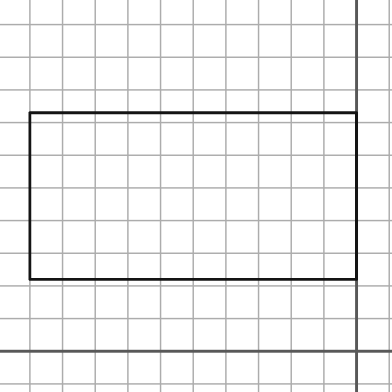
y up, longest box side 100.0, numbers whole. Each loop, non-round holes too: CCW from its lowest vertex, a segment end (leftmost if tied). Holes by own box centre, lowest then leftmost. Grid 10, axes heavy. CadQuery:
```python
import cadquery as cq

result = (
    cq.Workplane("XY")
    .moveTo(-100.0, 22.0)
    .lineTo(0.0, 22.0)
    .lineTo(0.0, 73.0)
    .lineTo(-100.0, 73.0)
    .close()
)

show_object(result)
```